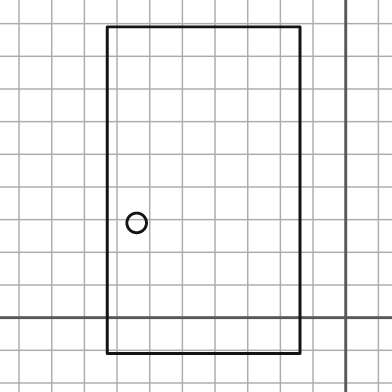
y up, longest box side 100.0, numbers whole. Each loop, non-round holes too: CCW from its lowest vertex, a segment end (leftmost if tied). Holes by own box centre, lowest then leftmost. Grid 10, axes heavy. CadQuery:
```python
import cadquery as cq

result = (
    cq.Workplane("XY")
    .moveTo(-73.0, -11.0)
    .lineTo(-14.0, -11.0)
    .lineTo(-14.0, 89.0)
    .lineTo(-73.0, 89.0)
    .close()
    .moveTo(-64.0, 29.0)
    .circle(3.0)
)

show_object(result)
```